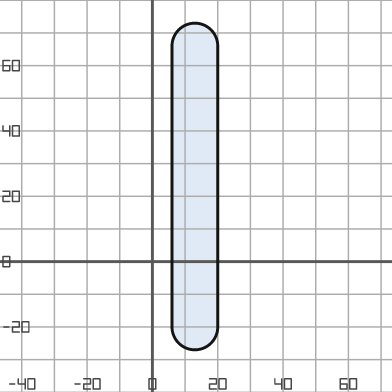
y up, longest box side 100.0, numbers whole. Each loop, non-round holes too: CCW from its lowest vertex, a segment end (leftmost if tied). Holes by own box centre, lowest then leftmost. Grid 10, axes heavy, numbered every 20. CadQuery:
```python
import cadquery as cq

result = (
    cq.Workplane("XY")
    .moveTo(6.0, -20.0)
    .threePointArc((13.0, -27.0), (20.0, -20.0))
    .lineTo(20.0, 66.0)
    .threePointArc((13.0, 73.0), (6.0, 66.0))
    .close()
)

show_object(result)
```